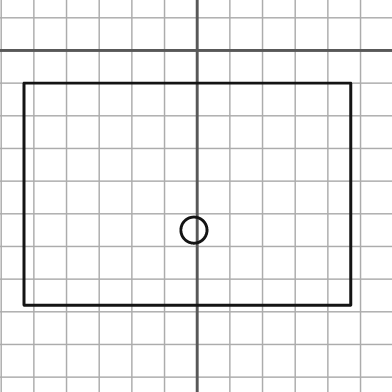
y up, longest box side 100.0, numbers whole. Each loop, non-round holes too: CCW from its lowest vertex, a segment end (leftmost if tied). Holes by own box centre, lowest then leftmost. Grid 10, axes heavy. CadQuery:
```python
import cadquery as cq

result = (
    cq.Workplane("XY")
    .moveTo(-53.0, -78.0)
    .lineTo(47.0, -78.0)
    .lineTo(47.0, -10.0)
    .lineTo(-53.0, -10.0)
    .close()
    .moveTo(-1.0, -55.0)
    .circle(4.0)
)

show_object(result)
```